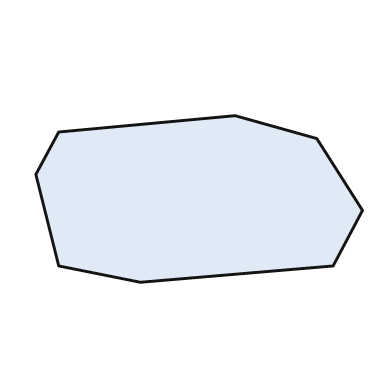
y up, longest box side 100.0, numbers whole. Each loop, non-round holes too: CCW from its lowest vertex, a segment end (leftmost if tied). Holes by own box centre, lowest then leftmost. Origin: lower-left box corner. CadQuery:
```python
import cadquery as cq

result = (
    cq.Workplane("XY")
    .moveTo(32.0, 0.0)
    .lineTo(91.0, 5.0)
    .lineTo(100.0, 22.0)
    .lineTo(86.0, 44.0)
    .lineTo(61.0, 51.0)
    .lineTo(7.0, 46.0)
    .lineTo(0.0, 33.0)
    .lineTo(7.0, 5.0)
    .close()
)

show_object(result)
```